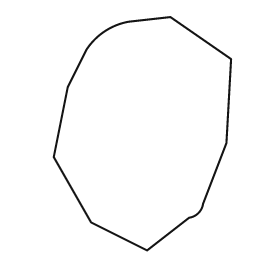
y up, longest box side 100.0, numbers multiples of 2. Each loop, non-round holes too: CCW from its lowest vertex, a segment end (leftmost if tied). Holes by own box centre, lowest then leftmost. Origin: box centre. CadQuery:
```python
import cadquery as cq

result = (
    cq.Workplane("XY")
    .moveTo(2.0, -50.0)
    .lineTo(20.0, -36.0)
    .threePointArc((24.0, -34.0), (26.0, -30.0))
    .lineTo(36.0, -4.0)
    .lineTo(38.0, 32.0)
    .lineTo(12.0, 50.0)
    .lineTo(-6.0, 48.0)
    .threePointArc((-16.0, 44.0), (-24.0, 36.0))
    .lineTo(-32.0, 20.0)
    .lineTo(-38.0, -10.0)
    .lineTo(-22.0, -38.0)
    .close()
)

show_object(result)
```